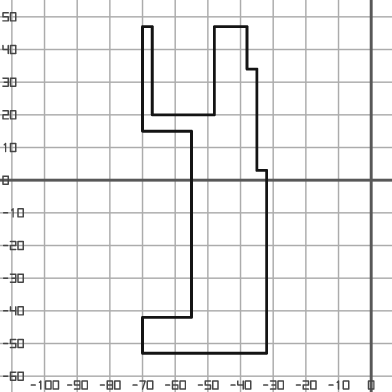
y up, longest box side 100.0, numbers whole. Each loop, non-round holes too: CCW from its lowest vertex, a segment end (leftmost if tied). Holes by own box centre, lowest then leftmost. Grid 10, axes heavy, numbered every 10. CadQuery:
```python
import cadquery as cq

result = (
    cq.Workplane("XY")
    .moveTo(-70.0, -53.0)
    .lineTo(-32.0, -53.0)
    .lineTo(-32.0, 3.0)
    .lineTo(-35.0, 3.0)
    .lineTo(-35.0, 34.0)
    .lineTo(-38.0, 34.0)
    .lineTo(-38.0, 47.0)
    .lineTo(-48.0, 47.0)
    .lineTo(-48.0, 20.0)
    .lineTo(-67.0, 20.0)
    .lineTo(-67.0, 47.0)
    .lineTo(-70.0, 47.0)
    .lineTo(-70.0, 15.0)
    .lineTo(-55.0, 15.0)
    .lineTo(-55.0, -42.0)
    .lineTo(-70.0, -42.0)
    .close()
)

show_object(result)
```